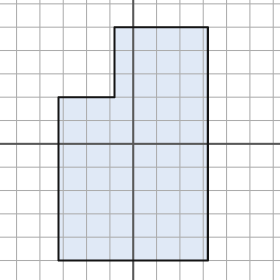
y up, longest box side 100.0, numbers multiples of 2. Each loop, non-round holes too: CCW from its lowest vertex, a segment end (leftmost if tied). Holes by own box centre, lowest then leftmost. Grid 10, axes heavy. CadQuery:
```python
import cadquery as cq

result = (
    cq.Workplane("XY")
    .moveTo(-32.0, -50.0)
    .lineTo(32.0, -50.0)
    .lineTo(32.0, 50.0)
    .lineTo(-8.0, 50.0)
    .lineTo(-8.0, 20.0)
    .lineTo(-32.0, 20.0)
    .close()
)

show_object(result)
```